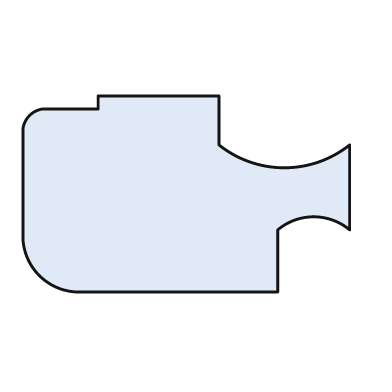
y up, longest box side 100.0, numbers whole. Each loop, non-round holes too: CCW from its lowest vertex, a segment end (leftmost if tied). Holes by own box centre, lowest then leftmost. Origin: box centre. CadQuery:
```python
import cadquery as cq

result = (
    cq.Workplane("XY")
    .moveTo(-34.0, -30.0)
    .lineTo(28.0, -30.0)
    .lineTo(28.0, -11.0)
    .threePointArc((39.0, -7.0), (50.0, -11.0))
    .lineTo(50.0, 15.0)
    .threePointArc((30.0, 8.0), (10.0, 15.0))
    .lineTo(10.0, 30.0)
    .lineTo(-27.0, 30.0)
    .lineTo(-27.0, 26.0)
    .lineTo(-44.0, 26.0)
    .threePointArc((-48.0, 24.0), (-50.0, 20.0))
    .lineTo(-50.0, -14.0)
    .threePointArc((-45.0, -25.0), (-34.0, -30.0))
    .close()
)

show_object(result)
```